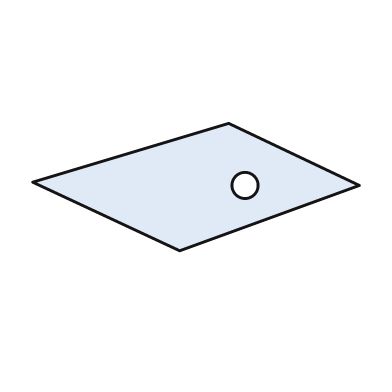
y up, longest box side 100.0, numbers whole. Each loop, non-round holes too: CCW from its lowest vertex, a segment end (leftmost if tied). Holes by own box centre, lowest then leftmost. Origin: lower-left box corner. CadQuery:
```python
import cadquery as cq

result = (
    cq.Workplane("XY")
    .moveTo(45.0, 0.0)
    .lineTo(100.0, 20.0)
    .lineTo(60.0, 39.0)
    .lineTo(0.0, 21.0)
    .close()
    .moveTo(65.0, 20.0)
    .circle(4.0)
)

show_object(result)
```